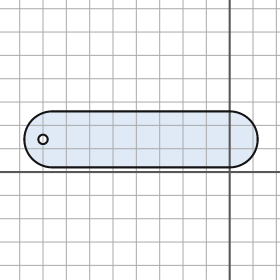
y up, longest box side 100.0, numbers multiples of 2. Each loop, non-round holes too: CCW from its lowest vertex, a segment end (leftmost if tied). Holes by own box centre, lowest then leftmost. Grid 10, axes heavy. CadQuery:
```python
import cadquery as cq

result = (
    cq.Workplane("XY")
    .moveTo(-76.0, 2.0)
    .lineTo(0.0, 2.0)
    .threePointArc((12.0, 14.0), (0.0, 26.0))
    .lineTo(-76.0, 26.0)
    .threePointArc((-88.0, 14.0), (-76.0, 2.0))
    .close()
    .moveTo(-80.0, 14.0)
    .circle(2.0)
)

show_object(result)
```